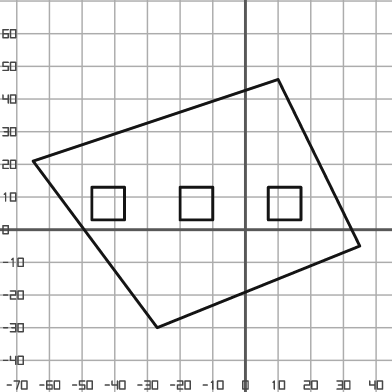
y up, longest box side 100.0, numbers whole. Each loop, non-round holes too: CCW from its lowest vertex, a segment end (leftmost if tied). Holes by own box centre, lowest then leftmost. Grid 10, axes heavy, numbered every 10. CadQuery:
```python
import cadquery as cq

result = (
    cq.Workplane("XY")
    .moveTo(-27.0, -30.0)
    .lineTo(35.0, -5.0)
    .lineTo(10.0, 46.0)
    .lineTo(-65.0, 21.0)
    .close()
    .moveTo(-47.0, 3.0)
    .lineTo(-37.0, 3.0)
    .lineTo(-37.0, 13.0)
    .lineTo(-47.0, 13.0)
    .close()
    .moveTo(-20.0, 3.0)
    .lineTo(-10.0, 3.0)
    .lineTo(-10.0, 13.0)
    .lineTo(-20.0, 13.0)
    .close()
    .moveTo(7.0, 3.0)
    .lineTo(17.0, 3.0)
    .lineTo(17.0, 13.0)
    .lineTo(7.0, 13.0)
    .close()
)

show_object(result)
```